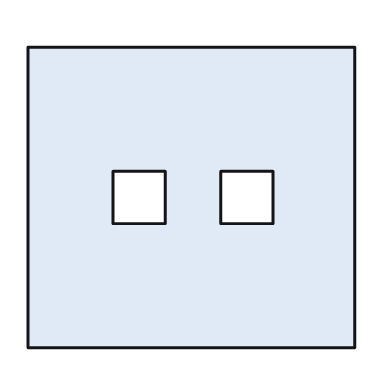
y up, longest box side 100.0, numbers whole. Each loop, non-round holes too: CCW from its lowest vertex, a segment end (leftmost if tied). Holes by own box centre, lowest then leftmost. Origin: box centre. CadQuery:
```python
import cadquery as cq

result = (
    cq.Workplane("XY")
    .moveTo(-50.0, -46.0)
    .lineTo(50.0, -46.0)
    .lineTo(50.0, 46.0)
    .lineTo(-50.0, 46.0)
    .close()
    .moveTo(-24.0, -8.0)
    .lineTo(-8.0, -8.0)
    .lineTo(-8.0, 8.0)
    .lineTo(-24.0, 8.0)
    .close()
    .moveTo(9.0, -8.0)
    .lineTo(25.0, -8.0)
    .lineTo(25.0, 8.0)
    .lineTo(9.0, 8.0)
    .close()
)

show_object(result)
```